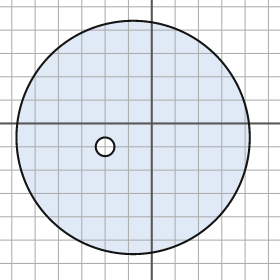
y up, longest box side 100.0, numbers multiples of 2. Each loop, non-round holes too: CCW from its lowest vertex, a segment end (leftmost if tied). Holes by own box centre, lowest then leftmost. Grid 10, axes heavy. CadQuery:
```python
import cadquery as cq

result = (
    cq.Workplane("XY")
    .moveTo(-8.0, -6.0)
    .circle(50.0)
    .moveTo(-20.0, -10.0)
    .circle(4.0)
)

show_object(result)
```